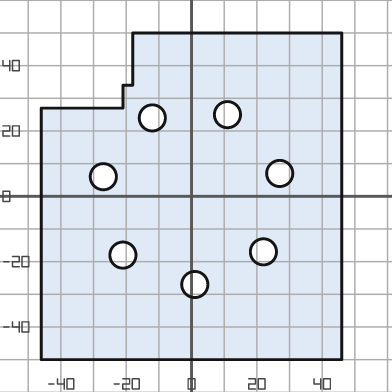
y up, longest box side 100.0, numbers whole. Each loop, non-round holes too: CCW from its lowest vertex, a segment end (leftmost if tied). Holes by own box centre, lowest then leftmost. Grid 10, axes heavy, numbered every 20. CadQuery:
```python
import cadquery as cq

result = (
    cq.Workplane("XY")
    .moveTo(-46.0, -50.0)
    .lineTo(46.0, -50.0)
    .lineTo(46.0, 50.0)
    .lineTo(-18.0, 50.0)
    .lineTo(-18.0, 34.0)
    .lineTo(-21.0, 34.0)
    .lineTo(-21.0, 27.0)
    .lineTo(-46.0, 27.0)
    .close()
    .moveTo(1.0, -27.0)
    .circle(4.0)
    .moveTo(-21.0, -18.0)
    .circle(4.0)
    .moveTo(22.0, -17.0)
    .circle(4.0)
    .moveTo(-27.0, 6.0)
    .circle(4.0)
    .moveTo(27.0, 7.0)
    .circle(4.0)
    .moveTo(-12.0, 24.0)
    .circle(4.0)
    .moveTo(11.0, 25.0)
    .circle(4.0)
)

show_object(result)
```